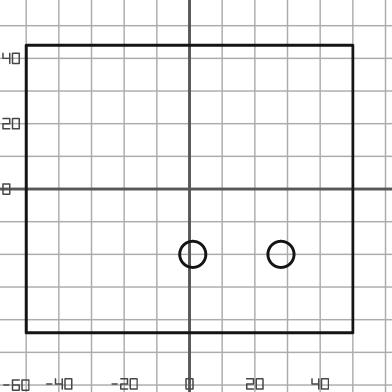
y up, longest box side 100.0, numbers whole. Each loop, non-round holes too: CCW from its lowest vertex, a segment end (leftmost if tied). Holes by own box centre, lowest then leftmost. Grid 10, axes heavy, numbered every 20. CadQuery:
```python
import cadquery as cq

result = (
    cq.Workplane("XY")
    .moveTo(-50.0, -44.0)
    .lineTo(50.0, -44.0)
    .lineTo(50.0, 44.0)
    .lineTo(-50.0, 44.0)
    .close()
    .moveTo(1.0, -20.0)
    .circle(4.0)
    .moveTo(28.0, -20.0)
    .circle(4.0)
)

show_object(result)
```